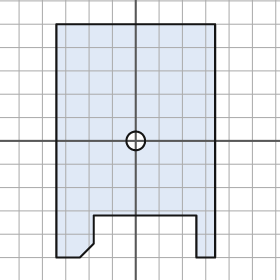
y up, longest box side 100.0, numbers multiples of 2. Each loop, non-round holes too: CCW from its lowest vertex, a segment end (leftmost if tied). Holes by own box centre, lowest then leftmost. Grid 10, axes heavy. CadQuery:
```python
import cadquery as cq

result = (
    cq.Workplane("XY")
    .moveTo(-34.0, -50.0)
    .lineTo(-24.0, -50.0)
    .lineTo(-18.0, -44.0)
    .lineTo(-18.0, -32.0)
    .lineTo(26.0, -32.0)
    .lineTo(26.0, -50.0)
    .lineTo(34.0, -50.0)
    .lineTo(34.0, 50.0)
    .lineTo(-34.0, 50.0)
    .close()
    .moveTo(0.0, 0.0)
    .circle(4.0)
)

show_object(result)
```